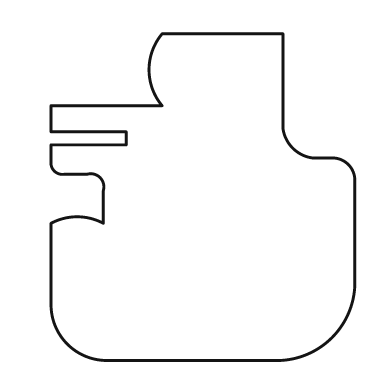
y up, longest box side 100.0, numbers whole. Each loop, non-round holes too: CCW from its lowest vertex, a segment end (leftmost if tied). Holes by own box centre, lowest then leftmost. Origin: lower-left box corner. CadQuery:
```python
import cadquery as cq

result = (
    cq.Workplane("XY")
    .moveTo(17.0, 0.0)
    .lineTo(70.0, 0.0)
    .threePointArc((86.0, 7.0), (93.0, 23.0))
    .lineTo(93.0, 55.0)
    .threePointArc((91.0, 60.0), (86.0, 62.0))
    .lineTo(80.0, 62.0)
    .threePointArc((74.0, 65.0), (71.0, 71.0))
    .lineTo(71.0, 100.0)
    .lineTo(34.0, 100.0)
    .threePointArc((30.0, 89.0), (34.0, 78.0))
    .lineTo(0.0, 78.0)
    .lineTo(0.0, 70.0)
    .lineTo(23.0, 70.0)
    .lineTo(23.0, 66.0)
    .lineTo(0.0, 66.0)
    .lineTo(0.0, 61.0)
    .threePointArc((1.0, 58.0), (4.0, 57.0))
    .lineTo(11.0, 57.0)
    .threePointArc((15.0, 56.0), (16.0, 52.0))
    .lineTo(16.0, 42.0)
    .threePointArc((8.0, 44.0), (0.0, 42.0))
    .lineTo(0.0, 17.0)
    .threePointArc((5.0, 5.0), (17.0, 0.0))
    .close()
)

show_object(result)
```